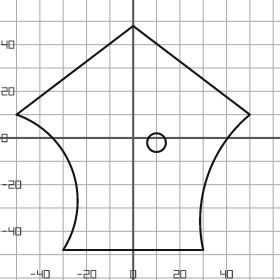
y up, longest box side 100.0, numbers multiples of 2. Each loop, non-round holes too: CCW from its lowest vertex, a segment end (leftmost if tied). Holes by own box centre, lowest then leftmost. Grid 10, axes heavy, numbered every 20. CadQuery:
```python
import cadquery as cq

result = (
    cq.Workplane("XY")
    .moveTo(-30.0, -48.0)
    .lineTo(30.0, -48.0)
    .threePointArc((32.0, -16.0), (50.0, 10.0))
    .lineTo(0.0, 48.0)
    .lineTo(-50.0, 10.0)
    .threePointArc((-26.0, -14.0), (-30.0, -48.0))
    .close()
    .moveTo(10.0, -2.0)
    .circle(4.0)
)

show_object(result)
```